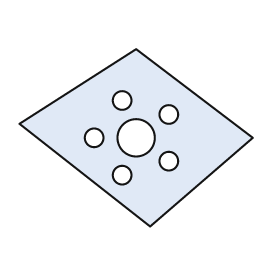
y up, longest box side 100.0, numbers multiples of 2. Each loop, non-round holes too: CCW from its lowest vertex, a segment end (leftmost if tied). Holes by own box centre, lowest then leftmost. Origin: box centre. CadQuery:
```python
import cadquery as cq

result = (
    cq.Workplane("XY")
    .moveTo(6.0, -38.0)
    .lineTo(50.0, 0.0)
    .lineTo(0.0, 38.0)
    .lineTo(-50.0, 6.0)
    .close()
    .moveTo(-6.0, -16.0)
    .circle(4.0)
    .moveTo(14.0, -10.0)
    .circle(4.0)
    .moveTo(-18.0, 0.0)
    .circle(4.0)
    .moveTo(0.0, 0.0)
    .circle(8.0)
    .moveTo(14.0, 10.0)
    .circle(4.0)
    .moveTo(-6.0, 16.0)
    .circle(4.0)
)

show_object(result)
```